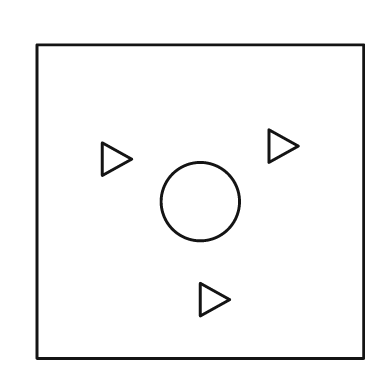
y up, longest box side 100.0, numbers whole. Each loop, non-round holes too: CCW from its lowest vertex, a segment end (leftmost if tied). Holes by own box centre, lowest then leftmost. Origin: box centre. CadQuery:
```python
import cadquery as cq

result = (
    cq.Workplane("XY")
    .moveTo(-50.0, -48.0)
    .lineTo(50.0, -48.0)
    .lineTo(50.0, 48.0)
    .lineTo(-50.0, 48.0)
    .close()
    .moveTo(0.0, -35.0)
    .lineTo(9.0, -30.0)
    .lineTo(0.0, -25.0)
    .close()
    .moveTo(0.0, 0.0)
    .circle(12.0)
    .moveTo(-30.0, 8.0)
    .lineTo(-21.0, 13.0)
    .lineTo(-30.0, 18.0)
    .close()
    .moveTo(21.0, 12.0)
    .lineTo(30.0, 17.0)
    .lineTo(21.0, 22.0)
    .close()
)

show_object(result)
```